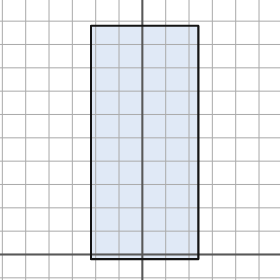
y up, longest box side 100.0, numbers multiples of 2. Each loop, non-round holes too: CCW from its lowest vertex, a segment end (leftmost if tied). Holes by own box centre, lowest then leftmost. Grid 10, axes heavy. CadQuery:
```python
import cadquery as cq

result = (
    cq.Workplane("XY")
    .moveTo(-22.0, -2.0)
    .lineTo(24.0, -2.0)
    .lineTo(24.0, 98.0)
    .lineTo(-22.0, 98.0)
    .close()
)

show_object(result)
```